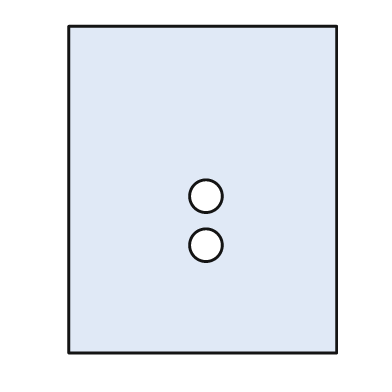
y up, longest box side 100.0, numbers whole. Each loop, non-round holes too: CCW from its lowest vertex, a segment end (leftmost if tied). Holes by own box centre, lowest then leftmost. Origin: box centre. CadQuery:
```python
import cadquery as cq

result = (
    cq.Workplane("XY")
    .moveTo(-41.0, -50.0)
    .lineTo(41.0, -50.0)
    .lineTo(41.0, 50.0)
    .lineTo(-41.0, 50.0)
    .close()
    .moveTo(1.0, -17.0)
    .circle(5.0)
    .moveTo(1.0, -2.0)
    .circle(5.0)
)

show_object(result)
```